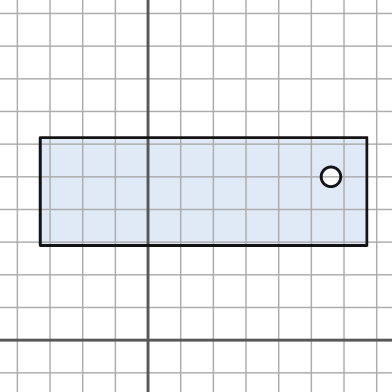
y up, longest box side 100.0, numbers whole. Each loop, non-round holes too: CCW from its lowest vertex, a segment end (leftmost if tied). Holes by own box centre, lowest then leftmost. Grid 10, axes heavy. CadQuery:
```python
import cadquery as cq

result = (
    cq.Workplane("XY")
    .moveTo(-33.0, 29.0)
    .lineTo(67.0, 29.0)
    .lineTo(67.0, 62.0)
    .lineTo(-33.0, 62.0)
    .close()
    .moveTo(56.0, 50.0)
    .circle(3.0)
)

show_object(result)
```